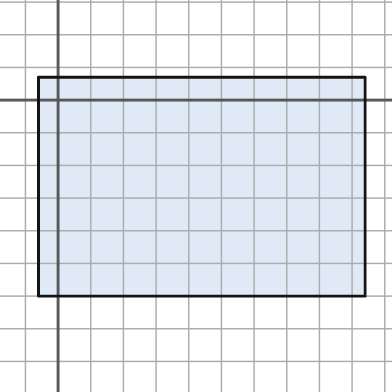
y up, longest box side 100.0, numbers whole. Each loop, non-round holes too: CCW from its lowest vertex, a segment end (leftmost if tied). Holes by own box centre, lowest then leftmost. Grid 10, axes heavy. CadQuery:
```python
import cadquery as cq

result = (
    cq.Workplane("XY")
    .moveTo(-6.0, -60.0)
    .lineTo(94.0, -60.0)
    .lineTo(94.0, 7.0)
    .lineTo(-6.0, 7.0)
    .close()
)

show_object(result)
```